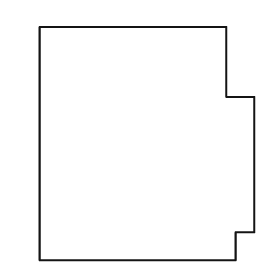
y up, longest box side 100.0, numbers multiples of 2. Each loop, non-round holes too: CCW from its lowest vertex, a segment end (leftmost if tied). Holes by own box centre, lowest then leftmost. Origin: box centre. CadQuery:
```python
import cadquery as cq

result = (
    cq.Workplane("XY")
    .moveTo(-46.0, -50.0)
    .lineTo(38.0, -50.0)
    .lineTo(38.0, -38.0)
    .lineTo(46.0, -38.0)
    .lineTo(46.0, 20.0)
    .lineTo(34.0, 20.0)
    .lineTo(34.0, 50.0)
    .lineTo(-46.0, 50.0)
    .close()
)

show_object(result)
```